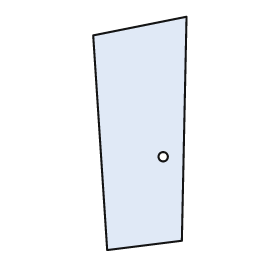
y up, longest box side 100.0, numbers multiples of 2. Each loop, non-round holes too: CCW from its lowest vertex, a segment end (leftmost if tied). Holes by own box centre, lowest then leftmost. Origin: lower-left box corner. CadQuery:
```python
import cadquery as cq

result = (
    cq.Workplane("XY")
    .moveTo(6.0, 0.0)
    .lineTo(38.0, 4.0)
    .lineTo(40.0, 100.0)
    .lineTo(0.0, 92.0)
    .close()
    .moveTo(30.0, 40.0)
    .circle(2.0)
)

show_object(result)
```